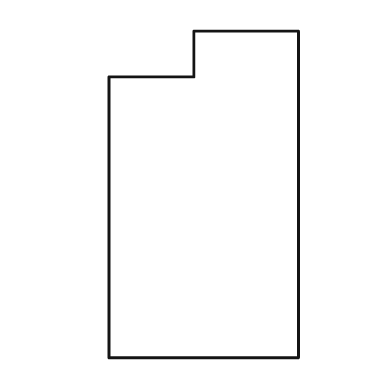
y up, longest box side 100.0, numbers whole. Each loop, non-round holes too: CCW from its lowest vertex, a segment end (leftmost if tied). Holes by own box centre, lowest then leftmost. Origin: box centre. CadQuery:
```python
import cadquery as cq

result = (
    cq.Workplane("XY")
    .moveTo(-29.0, -50.0)
    .lineTo(29.0, -50.0)
    .lineTo(29.0, 50.0)
    .lineTo(-3.0, 50.0)
    .lineTo(-3.0, 36.0)
    .lineTo(-29.0, 36.0)
    .close()
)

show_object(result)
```